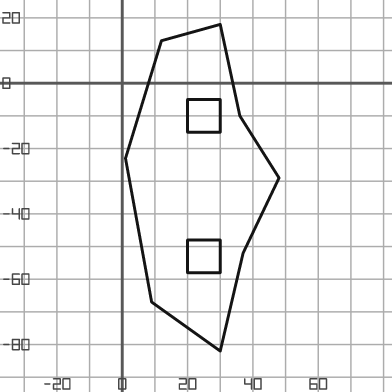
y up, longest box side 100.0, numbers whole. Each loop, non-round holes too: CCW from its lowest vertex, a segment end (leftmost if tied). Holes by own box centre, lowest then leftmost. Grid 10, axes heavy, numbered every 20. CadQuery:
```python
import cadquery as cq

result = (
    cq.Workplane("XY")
    .moveTo(30.0, -82.0)
    .lineTo(37.0, -52.0)
    .lineTo(48.0, -29.0)
    .lineTo(36.0, -10.0)
    .lineTo(30.0, 18.0)
    .lineTo(12.0, 13.0)
    .lineTo(1.0, -23.0)
    .lineTo(9.0, -67.0)
    .close()
    .moveTo(20.0, -58.0)
    .lineTo(30.0, -58.0)
    .lineTo(30.0, -48.0)
    .lineTo(20.0, -48.0)
    .close()
    .moveTo(20.0, -15.0)
    .lineTo(30.0, -15.0)
    .lineTo(30.0, -5.0)
    .lineTo(20.0, -5.0)
    .close()
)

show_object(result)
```